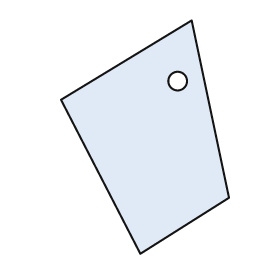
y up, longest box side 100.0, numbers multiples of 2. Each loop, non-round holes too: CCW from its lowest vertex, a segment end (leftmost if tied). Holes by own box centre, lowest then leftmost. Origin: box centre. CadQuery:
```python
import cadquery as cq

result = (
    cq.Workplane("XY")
    .moveTo(-2.0, -50.0)
    .lineTo(36.0, -26.0)
    .lineTo(20.0, 50.0)
    .lineTo(-36.0, 16.0)
    .close()
    .moveTo(14.0, 24.0)
    .circle(4.0)
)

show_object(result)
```